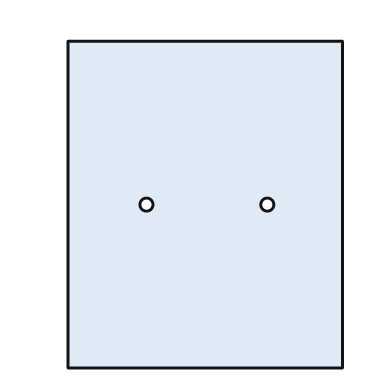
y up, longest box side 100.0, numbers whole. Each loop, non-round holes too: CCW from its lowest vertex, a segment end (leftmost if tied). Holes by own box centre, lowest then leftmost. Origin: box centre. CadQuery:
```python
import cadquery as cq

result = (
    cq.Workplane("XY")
    .moveTo(-42.0, -50.0)
    .lineTo(42.0, -50.0)
    .lineTo(42.0, 50.0)
    .lineTo(-42.0, 50.0)
    .close()
    .moveTo(-18.0, 0.0)
    .circle(2.0)
    .moveTo(19.0, 0.0)
    .circle(2.0)
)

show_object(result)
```